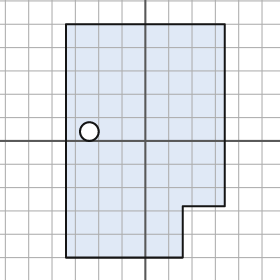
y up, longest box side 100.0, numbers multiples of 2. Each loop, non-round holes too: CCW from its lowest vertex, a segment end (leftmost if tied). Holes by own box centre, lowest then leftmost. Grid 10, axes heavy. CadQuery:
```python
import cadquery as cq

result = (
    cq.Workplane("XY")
    .moveTo(-34.0, -50.0)
    .lineTo(16.0, -50.0)
    .lineTo(16.0, -28.0)
    .lineTo(34.0, -28.0)
    .lineTo(34.0, 50.0)
    .lineTo(-34.0, 50.0)
    .close()
    .moveTo(-24.0, 4.0)
    .circle(4.0)
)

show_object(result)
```